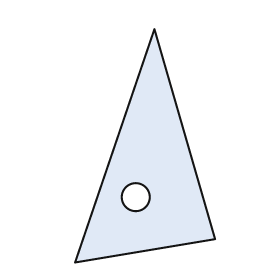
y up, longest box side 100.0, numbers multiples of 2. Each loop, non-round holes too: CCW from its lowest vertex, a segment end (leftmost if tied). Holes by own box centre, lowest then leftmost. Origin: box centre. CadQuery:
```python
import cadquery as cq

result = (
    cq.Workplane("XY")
    .moveTo(-30.0, -50.0)
    .lineTo(30.0, -40.0)
    .lineTo(4.0, 50.0)
    .close()
    .moveTo(-4.0, -22.0)
    .circle(6.0)
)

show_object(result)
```